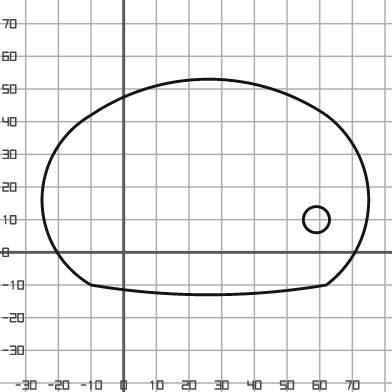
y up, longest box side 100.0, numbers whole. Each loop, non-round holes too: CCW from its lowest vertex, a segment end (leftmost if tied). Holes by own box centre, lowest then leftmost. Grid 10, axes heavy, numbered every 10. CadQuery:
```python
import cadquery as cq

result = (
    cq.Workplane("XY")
    .moveTo(-10.0, -10.0)
    .threePointArc((26.0, -13.0), (62.0, -10.0))
    .threePointArc((75.0, 16.0), (62.0, 42.0))
    .threePointArc((26.0, 53.0), (-10.0, 42.0))
    .threePointArc((-25.0, 16.0), (-10.0, -10.0))
    .close()
    .moveTo(59.0, 10.0)
    .circle(4.0)
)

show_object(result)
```